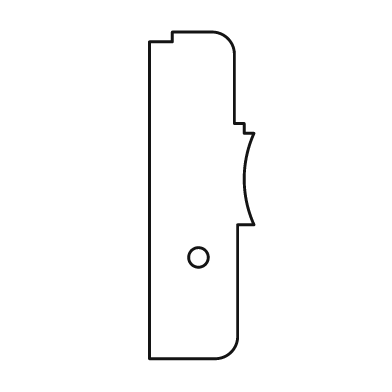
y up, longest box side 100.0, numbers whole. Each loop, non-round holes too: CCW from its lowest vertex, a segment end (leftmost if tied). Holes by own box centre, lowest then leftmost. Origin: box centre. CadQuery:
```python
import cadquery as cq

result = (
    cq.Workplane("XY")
    .moveTo(-16.0, -50.0)
    .lineTo(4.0, -50.0)
    .threePointArc((9.0, -48.0), (11.0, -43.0))
    .lineTo(11.0, -9.0)
    .lineTo(16.0, -9.0)
    .threePointArc((13.0, 5.0), (16.0, 19.0))
    .lineTo(13.0, 19.0)
    .lineTo(13.0, 22.0)
    .lineTo(10.0, 22.0)
    .lineTo(10.0, 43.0)
    .threePointArc((8.0, 48.0), (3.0, 50.0))
    .lineTo(-9.0, 50.0)
    .lineTo(-9.0, 47.0)
    .lineTo(-16.0, 47.0)
    .close()
    .moveTo(-1.0, -19.0)
    .circle(3.0)
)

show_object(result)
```